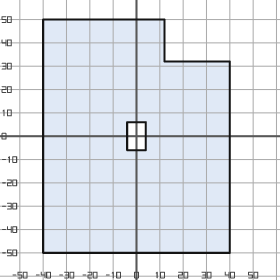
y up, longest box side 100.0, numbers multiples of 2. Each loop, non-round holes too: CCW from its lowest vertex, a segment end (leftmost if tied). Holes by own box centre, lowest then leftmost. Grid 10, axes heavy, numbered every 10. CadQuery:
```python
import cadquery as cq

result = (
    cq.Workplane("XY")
    .moveTo(-40.0, -50.0)
    .lineTo(40.0, -50.0)
    .lineTo(40.0, 32.0)
    .lineTo(12.0, 32.0)
    .lineTo(12.0, 50.0)
    .lineTo(-40.0, 50.0)
    .close()
    .moveTo(-4.0, -6.0)
    .lineTo(4.0, -6.0)
    .lineTo(4.0, 6.0)
    .lineTo(-4.0, 6.0)
    .close()
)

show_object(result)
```